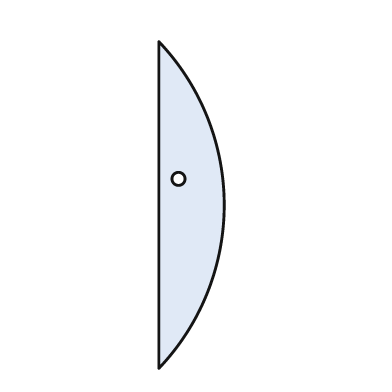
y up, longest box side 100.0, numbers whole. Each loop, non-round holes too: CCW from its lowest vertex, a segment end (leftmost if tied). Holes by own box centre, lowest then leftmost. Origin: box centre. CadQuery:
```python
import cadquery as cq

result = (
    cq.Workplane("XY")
    .moveTo(-10.0, -50.0)
    .threePointArc((10.0, 0.0), (-10.0, 50.0))
    .close()
    .moveTo(-4.0, 8.0)
    .circle(2.0)
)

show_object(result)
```